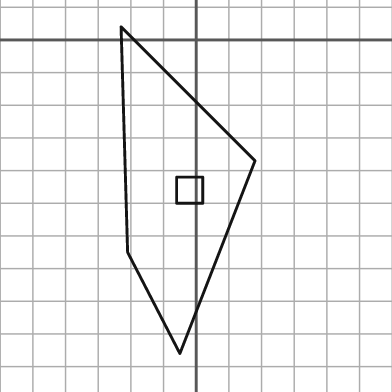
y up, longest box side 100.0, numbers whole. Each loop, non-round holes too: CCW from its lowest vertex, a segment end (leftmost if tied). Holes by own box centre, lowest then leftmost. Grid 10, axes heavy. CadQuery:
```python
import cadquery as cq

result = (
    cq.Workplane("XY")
    .moveTo(-5.0, -96.0)
    .lineTo(18.0, -37.0)
    .lineTo(-23.0, 4.0)
    .lineTo(-21.0, -65.0)
    .close()
    .moveTo(-6.0, -50.0)
    .lineTo(2.0, -50.0)
    .lineTo(2.0, -42.0)
    .lineTo(-6.0, -42.0)
    .close()
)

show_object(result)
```